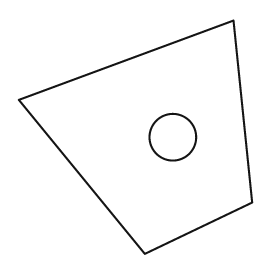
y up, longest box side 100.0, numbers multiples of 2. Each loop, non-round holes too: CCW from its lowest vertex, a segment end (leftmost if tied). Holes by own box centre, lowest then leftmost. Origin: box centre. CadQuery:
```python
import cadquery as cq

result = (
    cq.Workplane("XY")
    .moveTo(4.0, -50.0)
    .lineTo(50.0, -28.0)
    .lineTo(42.0, 50.0)
    .lineTo(-50.0, 16.0)
    .close()
    .moveTo(16.0, 0.0)
    .circle(10.0)
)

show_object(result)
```